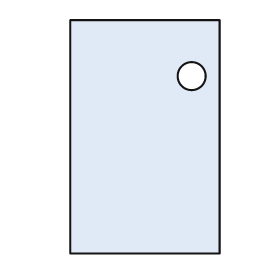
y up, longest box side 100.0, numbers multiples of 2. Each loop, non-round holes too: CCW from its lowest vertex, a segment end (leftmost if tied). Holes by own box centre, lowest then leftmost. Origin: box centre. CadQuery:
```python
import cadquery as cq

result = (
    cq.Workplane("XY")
    .moveTo(-32.0, -50.0)
    .lineTo(32.0, -50.0)
    .lineTo(32.0, 50.0)
    .lineTo(-32.0, 50.0)
    .close()
    .moveTo(20.0, 26.0)
    .circle(6.0)
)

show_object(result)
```